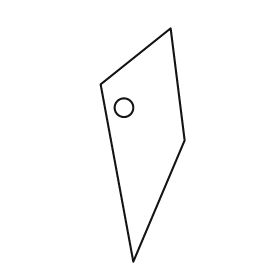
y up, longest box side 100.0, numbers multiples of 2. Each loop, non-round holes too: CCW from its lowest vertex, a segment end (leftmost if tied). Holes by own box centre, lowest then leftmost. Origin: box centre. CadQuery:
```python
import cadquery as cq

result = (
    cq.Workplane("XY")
    .moveTo(-4.0, -50.0)
    .lineTo(18.0, 2.0)
    .lineTo(12.0, 50.0)
    .lineTo(-18.0, 26.0)
    .close()
    .moveTo(-8.0, 16.0)
    .circle(4.0)
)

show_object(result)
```